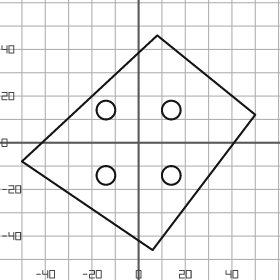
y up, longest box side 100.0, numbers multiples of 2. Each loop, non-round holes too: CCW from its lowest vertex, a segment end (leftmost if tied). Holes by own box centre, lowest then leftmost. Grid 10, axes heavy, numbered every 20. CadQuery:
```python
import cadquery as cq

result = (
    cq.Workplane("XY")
    .moveTo(6.0, -46.0)
    .lineTo(50.0, 12.0)
    .lineTo(8.0, 46.0)
    .lineTo(-50.0, -8.0)
    .close()
    .moveTo(-14.0, -14.0)
    .circle(4.0)
    .moveTo(14.0, -14.0)
    .circle(4.0)
    .moveTo(-14.0, 14.0)
    .circle(4.0)
    .moveTo(14.0, 14.0)
    .circle(4.0)
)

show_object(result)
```